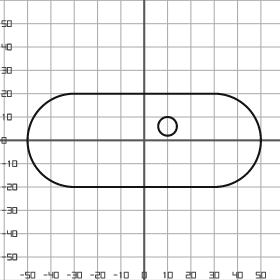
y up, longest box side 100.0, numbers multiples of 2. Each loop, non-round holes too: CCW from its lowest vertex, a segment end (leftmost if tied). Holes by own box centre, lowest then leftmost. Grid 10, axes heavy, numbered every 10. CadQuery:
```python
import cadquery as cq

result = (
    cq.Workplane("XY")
    .moveTo(-30.0, -20.0)
    .lineTo(30.0, -20.0)
    .threePointArc((50.0, 0.0), (30.0, 20.0))
    .lineTo(-30.0, 20.0)
    .threePointArc((-50.0, 0.0), (-30.0, -20.0))
    .close()
    .moveTo(10.0, 6.0)
    .circle(4.0)
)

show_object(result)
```